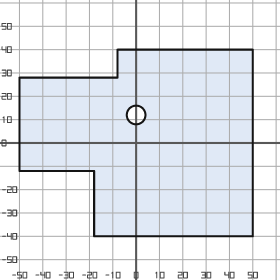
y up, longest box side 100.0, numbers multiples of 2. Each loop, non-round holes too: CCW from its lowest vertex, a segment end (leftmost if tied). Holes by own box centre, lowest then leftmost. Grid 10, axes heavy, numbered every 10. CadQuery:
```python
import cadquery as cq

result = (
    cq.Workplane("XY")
    .moveTo(-18.0, -40.0)
    .lineTo(50.0, -40.0)
    .lineTo(50.0, 40.0)
    .lineTo(-8.0, 40.0)
    .lineTo(-8.0, 28.0)
    .lineTo(-50.0, 28.0)
    .lineTo(-50.0, -12.0)
    .lineTo(-18.0, -12.0)
    .close()
    .moveTo(0.0, 12.0)
    .circle(4.0)
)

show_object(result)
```